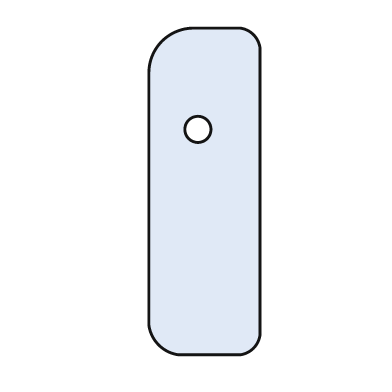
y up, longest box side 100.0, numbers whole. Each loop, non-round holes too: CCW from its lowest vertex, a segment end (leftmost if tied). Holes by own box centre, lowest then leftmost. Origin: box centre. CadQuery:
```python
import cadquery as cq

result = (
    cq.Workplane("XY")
    .moveTo(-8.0, -50.0)
    .lineTo(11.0, -50.0)
    .threePointArc((15.0, -48.0), (17.0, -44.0))
    .lineTo(17.0, 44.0)
    .threePointArc((15.0, 48.0), (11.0, 50.0))
    .lineTo(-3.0, 50.0)
    .threePointArc((-13.0, 46.0), (-17.0, 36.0))
    .lineTo(-17.0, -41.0)
    .threePointArc((-14.0, -47.0), (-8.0, -50.0))
    .close()
    .moveTo(-2.0, 19.0)
    .circle(4.0)
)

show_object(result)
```